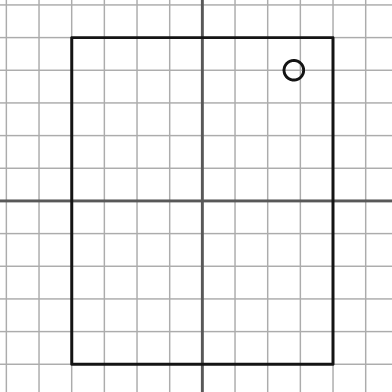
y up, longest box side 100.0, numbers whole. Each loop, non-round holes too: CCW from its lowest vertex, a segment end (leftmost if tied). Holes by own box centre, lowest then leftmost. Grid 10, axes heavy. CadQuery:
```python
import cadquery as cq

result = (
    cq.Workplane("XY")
    .moveTo(-40.0, -50.0)
    .lineTo(40.0, -50.0)
    .lineTo(40.0, 50.0)
    .lineTo(-40.0, 50.0)
    .close()
    .moveTo(28.0, 40.0)
    .circle(3.0)
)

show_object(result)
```